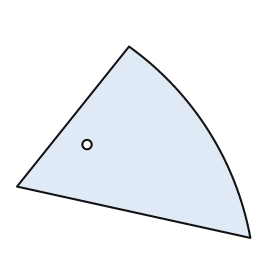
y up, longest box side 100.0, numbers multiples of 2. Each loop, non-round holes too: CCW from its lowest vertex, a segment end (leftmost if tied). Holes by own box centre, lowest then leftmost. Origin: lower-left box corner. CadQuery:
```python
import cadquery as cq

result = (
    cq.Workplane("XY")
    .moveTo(100.0, 0.0)
    .threePointArc((82.0, 46.0), (48.0, 82.0))
    .lineTo(0.0, 22.0)
    .close()
    .moveTo(30.0, 40.0)
    .circle(2.0)
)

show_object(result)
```